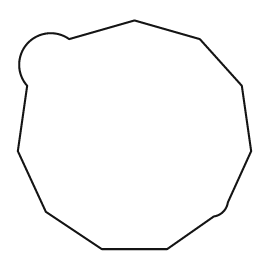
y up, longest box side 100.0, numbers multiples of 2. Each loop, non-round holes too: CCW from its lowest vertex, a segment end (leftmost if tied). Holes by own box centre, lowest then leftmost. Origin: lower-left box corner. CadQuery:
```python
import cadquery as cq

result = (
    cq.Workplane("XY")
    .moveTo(36.0, 0.0)
    .lineTo(64.0, 0.0)
    .lineTo(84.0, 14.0)
    .threePointArc((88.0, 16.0), (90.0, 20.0))
    .lineTo(100.0, 42.0)
    .lineTo(96.0, 70.0)
    .lineTo(78.0, 90.0)
    .lineTo(50.0, 98.0)
    .lineTo(22.0, 90.0)
    .threePointArc((4.0, 88.0), (4.0, 70.0))
    .lineTo(0.0, 42.0)
    .lineTo(12.0, 16.0)
    .close()
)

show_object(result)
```